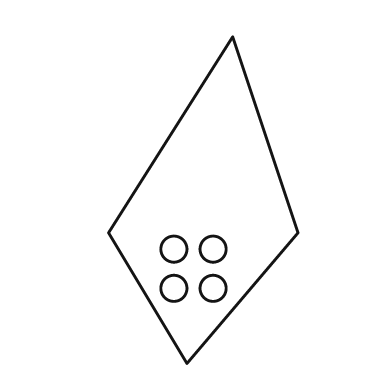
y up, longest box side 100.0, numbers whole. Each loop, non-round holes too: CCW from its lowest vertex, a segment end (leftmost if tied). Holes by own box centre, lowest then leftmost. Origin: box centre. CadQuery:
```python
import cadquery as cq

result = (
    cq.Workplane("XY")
    .moveTo(-5.0, -50.0)
    .lineTo(29.0, -10.0)
    .lineTo(9.0, 50.0)
    .lineTo(-29.0, -10.0)
    .close()
    .moveTo(-9.0, -27.0)
    .circle(4.0)
    .moveTo(3.0, -27.0)
    .circle(4.0)
    .moveTo(-9.0, -15.0)
    .circle(4.0)
    .moveTo(3.0, -15.0)
    .circle(4.0)
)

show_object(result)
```